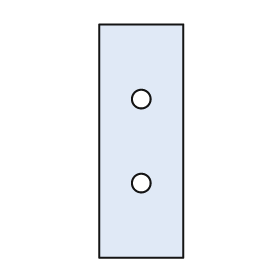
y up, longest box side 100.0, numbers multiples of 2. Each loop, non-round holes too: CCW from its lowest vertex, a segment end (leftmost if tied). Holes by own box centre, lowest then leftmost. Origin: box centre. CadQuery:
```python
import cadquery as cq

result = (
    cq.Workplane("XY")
    .moveTo(-18.0, -50.0)
    .lineTo(18.0, -50.0)
    .lineTo(18.0, 50.0)
    .lineTo(-18.0, 50.0)
    .close()
    .moveTo(0.0, -18.0)
    .circle(4.0)
    .moveTo(0.0, 18.0)
    .circle(4.0)
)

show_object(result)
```